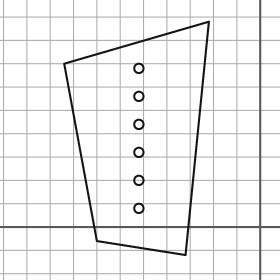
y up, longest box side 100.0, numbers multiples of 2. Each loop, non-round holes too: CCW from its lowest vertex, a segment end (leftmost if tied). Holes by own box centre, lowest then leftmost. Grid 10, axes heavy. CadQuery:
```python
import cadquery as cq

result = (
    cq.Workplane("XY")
    .moveTo(-32.0, -12.0)
    .lineTo(-22.0, 88.0)
    .lineTo(-84.0, 70.0)
    .lineTo(-70.0, -6.0)
    .close()
    .moveTo(-52.0, 8.0)
    .circle(2.0)
    .moveTo(-52.0, 20.0)
    .circle(2.0)
    .moveTo(-52.0, 32.0)
    .circle(2.0)
    .moveTo(-52.0, 44.0)
    .circle(2.0)
    .moveTo(-52.0, 56.0)
    .circle(2.0)
    .moveTo(-52.0, 68.0)
    .circle(2.0)
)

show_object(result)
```